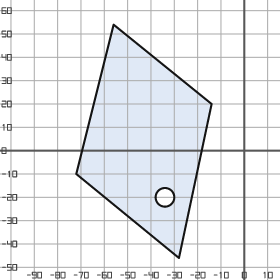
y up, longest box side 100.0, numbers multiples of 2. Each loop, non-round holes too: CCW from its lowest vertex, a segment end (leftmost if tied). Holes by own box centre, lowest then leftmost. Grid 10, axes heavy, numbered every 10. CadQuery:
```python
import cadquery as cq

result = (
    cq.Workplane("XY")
    .moveTo(-28.0, -46.0)
    .lineTo(-14.0, 20.0)
    .lineTo(-56.0, 54.0)
    .lineTo(-72.0, -10.0)
    .close()
    .moveTo(-34.0, -20.0)
    .circle(4.0)
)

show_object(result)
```